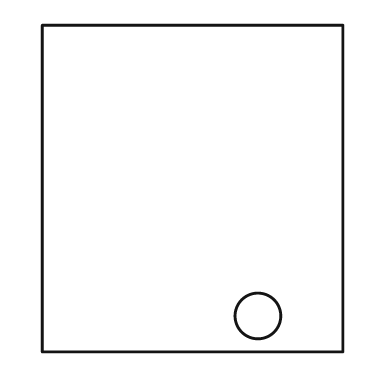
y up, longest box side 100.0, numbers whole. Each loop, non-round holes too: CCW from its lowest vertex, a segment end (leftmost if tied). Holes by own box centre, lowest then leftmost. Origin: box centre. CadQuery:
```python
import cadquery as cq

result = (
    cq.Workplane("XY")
    .moveTo(-46.0, -50.0)
    .lineTo(46.0, -50.0)
    .lineTo(46.0, 50.0)
    .lineTo(-46.0, 50.0)
    .close()
    .moveTo(20.0, -39.0)
    .circle(7.0)
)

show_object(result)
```